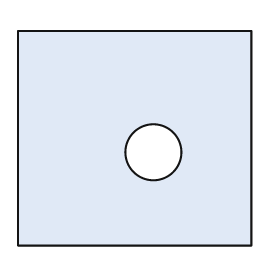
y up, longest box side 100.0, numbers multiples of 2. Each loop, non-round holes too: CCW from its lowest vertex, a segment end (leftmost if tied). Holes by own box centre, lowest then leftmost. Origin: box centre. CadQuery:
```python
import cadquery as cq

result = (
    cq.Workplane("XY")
    .moveTo(-50.0, -46.0)
    .lineTo(50.0, -46.0)
    .lineTo(50.0, 46.0)
    .lineTo(-50.0, 46.0)
    .close()
    .moveTo(8.0, -6.0)
    .circle(12.0)
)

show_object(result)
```